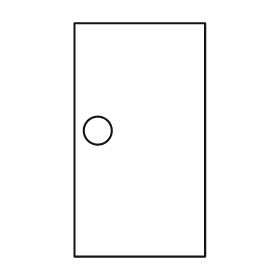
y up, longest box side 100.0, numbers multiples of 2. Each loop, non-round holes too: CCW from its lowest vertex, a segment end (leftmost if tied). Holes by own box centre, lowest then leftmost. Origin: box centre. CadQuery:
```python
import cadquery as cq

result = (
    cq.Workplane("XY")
    .moveTo(-28.0, -50.0)
    .lineTo(28.0, -50.0)
    .lineTo(28.0, 50.0)
    .lineTo(-28.0, 50.0)
    .close()
    .moveTo(-18.0, 4.0)
    .circle(6.0)
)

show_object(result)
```